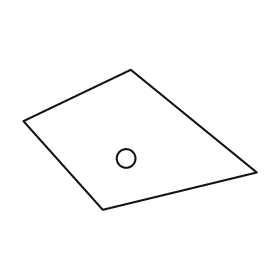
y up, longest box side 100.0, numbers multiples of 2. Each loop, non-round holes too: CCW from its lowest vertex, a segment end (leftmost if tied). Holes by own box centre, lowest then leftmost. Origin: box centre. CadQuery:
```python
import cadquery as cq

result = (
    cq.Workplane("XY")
    .moveTo(-16.0, -30.0)
    .lineTo(50.0, -14.0)
    .lineTo(-4.0, 30.0)
    .lineTo(-50.0, 8.0)
    .close()
    .moveTo(-6.0, -8.0)
    .circle(4.0)
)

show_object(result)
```